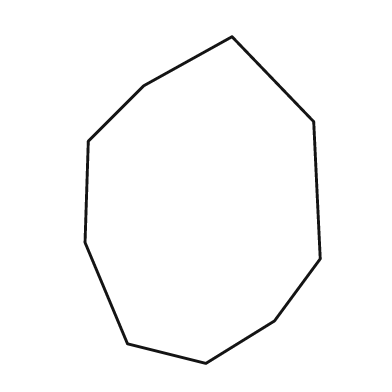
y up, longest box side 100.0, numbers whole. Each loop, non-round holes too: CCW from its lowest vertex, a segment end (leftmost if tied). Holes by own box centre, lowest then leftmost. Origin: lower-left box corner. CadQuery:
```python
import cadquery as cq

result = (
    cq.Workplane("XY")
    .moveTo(37.0, 0.0)
    .lineTo(58.0, 13.0)
    .lineTo(72.0, 32.0)
    .lineTo(70.0, 74.0)
    .lineTo(45.0, 100.0)
    .lineTo(18.0, 85.0)
    .lineTo(1.0, 68.0)
    .lineTo(0.0, 37.0)
    .lineTo(13.0, 6.0)
    .close()
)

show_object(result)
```